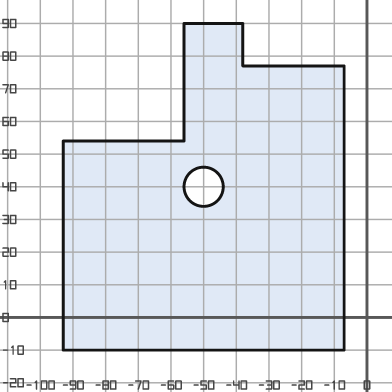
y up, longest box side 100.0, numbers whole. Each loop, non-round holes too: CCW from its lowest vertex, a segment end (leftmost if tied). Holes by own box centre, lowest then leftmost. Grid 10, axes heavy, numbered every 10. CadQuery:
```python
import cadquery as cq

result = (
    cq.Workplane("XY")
    .moveTo(-93.0, -10.0)
    .lineTo(-7.0, -10.0)
    .lineTo(-7.0, 77.0)
    .lineTo(-38.0, 77.0)
    .lineTo(-38.0, 90.0)
    .lineTo(-56.0, 90.0)
    .lineTo(-56.0, 54.0)
    .lineTo(-93.0, 54.0)
    .close()
    .moveTo(-50.0, 40.0)
    .circle(6.0)
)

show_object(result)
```